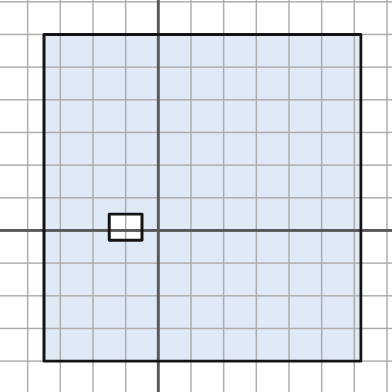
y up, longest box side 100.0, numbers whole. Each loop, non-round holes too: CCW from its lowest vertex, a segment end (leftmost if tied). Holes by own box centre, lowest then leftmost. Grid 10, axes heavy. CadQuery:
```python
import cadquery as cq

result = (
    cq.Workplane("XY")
    .moveTo(-35.0, -40.0)
    .lineTo(62.0, -40.0)
    .lineTo(62.0, 60.0)
    .lineTo(-35.0, 60.0)
    .close()
    .moveTo(-15.0, -3.0)
    .lineTo(-5.0, -3.0)
    .lineTo(-5.0, 5.0)
    .lineTo(-15.0, 5.0)
    .close()
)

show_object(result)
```